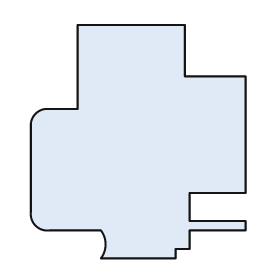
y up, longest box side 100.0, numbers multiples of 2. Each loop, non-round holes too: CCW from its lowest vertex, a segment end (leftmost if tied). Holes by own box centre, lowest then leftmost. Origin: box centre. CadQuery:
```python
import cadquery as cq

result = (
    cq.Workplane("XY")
    .moveTo(-16.0, -50.0)
    .lineTo(16.0, -50.0)
    .lineTo(16.0, -46.0)
    .lineTo(22.0, -46.0)
    .lineTo(22.0, -38.0)
    .lineTo(46.0, -38.0)
    .lineTo(46.0, -34.0)
    .lineTo(22.0, -34.0)
    .lineTo(22.0, -22.0)
    .lineTo(46.0, -22.0)
    .lineTo(46.0, 28.0)
    .lineTo(20.0, 28.0)
    .lineTo(20.0, 50.0)
    .lineTo(-26.0, 50.0)
    .lineTo(-26.0, 14.0)
    .lineTo(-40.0, 14.0)
    .threePointArc((-44.0, 12.0), (-46.0, 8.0))
    .lineTo(-46.0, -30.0)
    .threePointArc((-44.0, -36.0), (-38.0, -38.0))
    .lineTo(-16.0, -38.0)
    .threePointArc((-14.0, -44.0), (-16.0, -50.0))
    .close()
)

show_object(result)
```